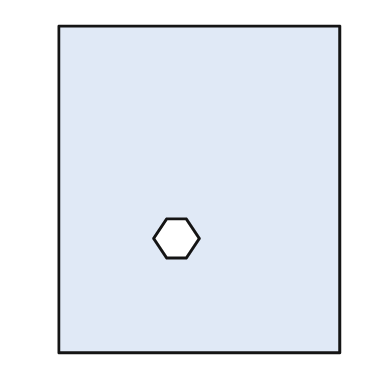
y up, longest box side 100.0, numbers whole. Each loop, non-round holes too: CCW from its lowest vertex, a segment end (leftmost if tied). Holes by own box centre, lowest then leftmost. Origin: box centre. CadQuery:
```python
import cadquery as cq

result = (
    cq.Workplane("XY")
    .moveTo(-43.0, -50.0)
    .lineTo(43.0, -50.0)
    .lineTo(43.0, 50.0)
    .lineTo(-43.0, 50.0)
    .close()
    .moveTo(-10.0, -21.0)
    .lineTo(-4.0, -21.0)
    .lineTo(0.0, -15.0)
    .lineTo(-4.0, -9.0)
    .lineTo(-10.0, -9.0)
    .lineTo(-14.0, -15.0)
    .close()
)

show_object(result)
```